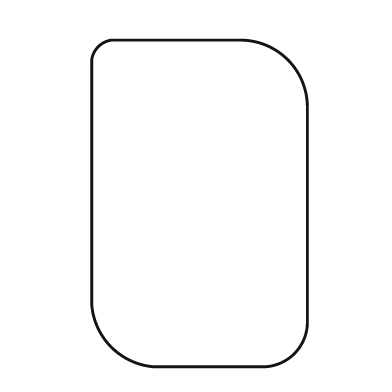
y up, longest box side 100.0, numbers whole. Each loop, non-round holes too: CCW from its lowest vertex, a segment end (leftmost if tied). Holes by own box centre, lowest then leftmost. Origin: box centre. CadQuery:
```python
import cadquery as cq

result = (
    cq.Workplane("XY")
    .moveTo(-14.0, -50.0)
    .lineTo(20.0, -50.0)
    .threePointArc((29.0, -46.0), (33.0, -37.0))
    .lineTo(33.0, 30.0)
    .threePointArc((27.0, 44.0), (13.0, 50.0))
    .lineTo(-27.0, 50.0)
    .threePointArc((-31.0, 48.0), (-33.0, 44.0))
    .lineTo(-33.0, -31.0)
    .threePointArc((-27.0, -44.0), (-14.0, -50.0))
    .close()
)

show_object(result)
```